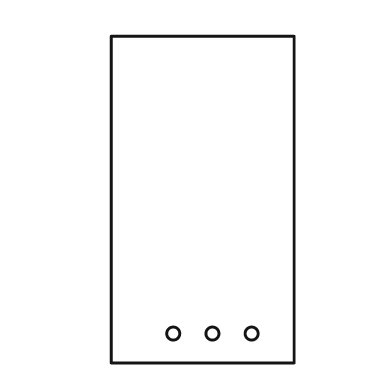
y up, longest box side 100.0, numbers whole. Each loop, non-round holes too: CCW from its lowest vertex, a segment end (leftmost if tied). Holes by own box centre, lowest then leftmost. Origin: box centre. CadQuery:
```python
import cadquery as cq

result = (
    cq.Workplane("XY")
    .moveTo(-28.0, -50.0)
    .lineTo(28.0, -50.0)
    .lineTo(28.0, 50.0)
    .lineTo(-28.0, 50.0)
    .close()
    .moveTo(-9.0, -41.0)
    .circle(2.0)
    .moveTo(3.0, -41.0)
    .circle(2.0)
    .moveTo(15.0, -41.0)
    .circle(2.0)
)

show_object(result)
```